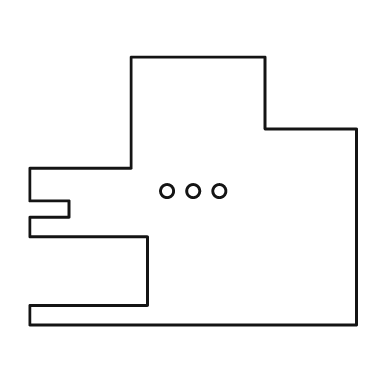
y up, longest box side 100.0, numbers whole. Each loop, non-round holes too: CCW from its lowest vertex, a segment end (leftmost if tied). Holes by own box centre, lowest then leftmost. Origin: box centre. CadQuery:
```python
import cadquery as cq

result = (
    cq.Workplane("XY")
    .moveTo(-50.0, -41.0)
    .lineTo(50.0, -41.0)
    .lineTo(50.0, 19.0)
    .lineTo(22.0, 19.0)
    .lineTo(22.0, 41.0)
    .lineTo(-19.0, 41.0)
    .lineTo(-19.0, 7.0)
    .lineTo(-50.0, 7.0)
    .lineTo(-50.0, -3.0)
    .lineTo(-38.0, -3.0)
    .lineTo(-38.0, -8.0)
    .lineTo(-50.0, -8.0)
    .lineTo(-50.0, -14.0)
    .lineTo(-14.0, -14.0)
    .lineTo(-14.0, -35.0)
    .lineTo(-50.0, -35.0)
    .close()
    .moveTo(-8.0, 0.0)
    .circle(2.0)
    .moveTo(0.0, 0.0)
    .circle(2.0)
    .moveTo(8.0, 0.0)
    .circle(2.0)
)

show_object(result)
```